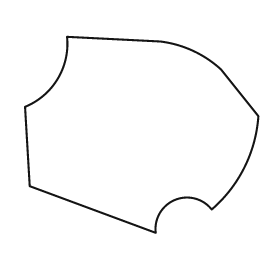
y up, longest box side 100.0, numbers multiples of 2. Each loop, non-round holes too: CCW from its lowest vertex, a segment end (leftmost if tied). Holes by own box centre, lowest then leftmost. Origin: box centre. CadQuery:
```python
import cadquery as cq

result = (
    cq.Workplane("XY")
    .moveTo(6.0, -42.0)
    .threePointArc((14.0, -28.0), (30.0, -32.0))
    .threePointArc((44.0, -14.0), (50.0, 8.0))
    .lineTo(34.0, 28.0)
    .threePointArc((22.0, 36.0), (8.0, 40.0))
    .lineTo(-32.0, 42.0)
    .threePointArc((-36.0, 24.0), (-50.0, 12.0))
    .lineTo(-48.0, -22.0)
    .close()
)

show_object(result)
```